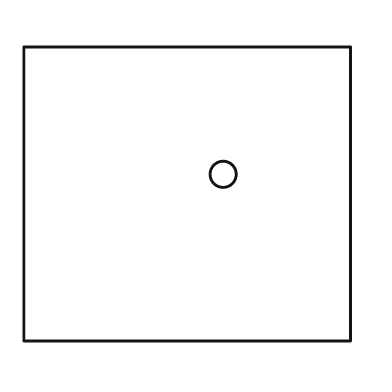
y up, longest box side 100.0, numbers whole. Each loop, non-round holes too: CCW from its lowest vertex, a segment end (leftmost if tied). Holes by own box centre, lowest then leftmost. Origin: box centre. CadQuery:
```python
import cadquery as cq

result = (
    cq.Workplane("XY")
    .moveTo(-50.0, -45.0)
    .lineTo(50.0, -45.0)
    .lineTo(50.0, 45.0)
    .lineTo(-50.0, 45.0)
    .close()
    .moveTo(11.0, 6.0)
    .circle(4.0)
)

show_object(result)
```